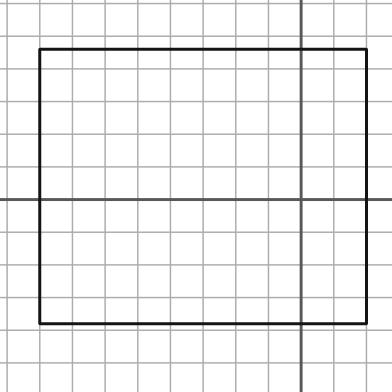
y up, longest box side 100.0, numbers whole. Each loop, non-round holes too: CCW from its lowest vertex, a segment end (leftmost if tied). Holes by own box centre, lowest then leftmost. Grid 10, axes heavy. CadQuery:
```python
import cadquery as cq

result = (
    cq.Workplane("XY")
    .moveTo(-80.0, -38.0)
    .lineTo(20.0, -38.0)
    .lineTo(20.0, 46.0)
    .lineTo(-80.0, 46.0)
    .close()
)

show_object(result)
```